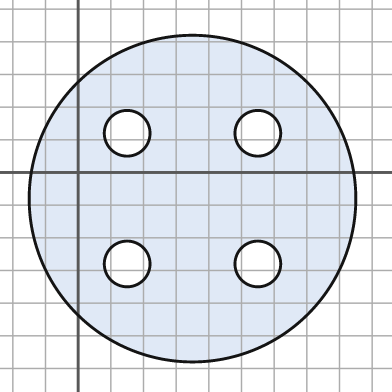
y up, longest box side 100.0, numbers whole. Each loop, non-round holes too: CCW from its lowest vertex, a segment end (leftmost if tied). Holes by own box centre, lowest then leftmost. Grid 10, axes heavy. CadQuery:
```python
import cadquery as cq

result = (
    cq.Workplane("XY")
    .moveTo(35.0, -8.0)
    .circle(50.0)
    .moveTo(15.0, -28.0)
    .circle(7.0)
    .moveTo(55.0, -28.0)
    .circle(7.0)
    .moveTo(15.0, 12.0)
    .circle(7.0)
    .moveTo(55.0, 12.0)
    .circle(7.0)
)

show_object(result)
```